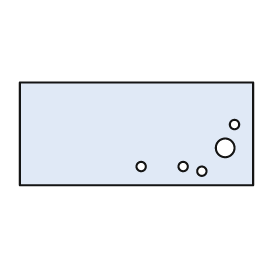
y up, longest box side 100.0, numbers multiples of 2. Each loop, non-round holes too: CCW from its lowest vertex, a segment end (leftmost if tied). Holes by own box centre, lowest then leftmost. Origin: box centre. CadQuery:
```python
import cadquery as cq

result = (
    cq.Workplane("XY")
    .moveTo(-50.0, -22.0)
    .lineTo(50.0, -22.0)
    .lineTo(50.0, 22.0)
    .lineTo(-50.0, 22.0)
    .close()
    .moveTo(28.0, -16.0)
    .circle(2.0)
    .moveTo(2.0, -14.0)
    .circle(2.0)
    .moveTo(20.0, -14.0)
    .circle(2.0)
    .moveTo(38.0, -6.0)
    .circle(4.0)
    .moveTo(42.0, 4.0)
    .circle(2.0)
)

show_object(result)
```